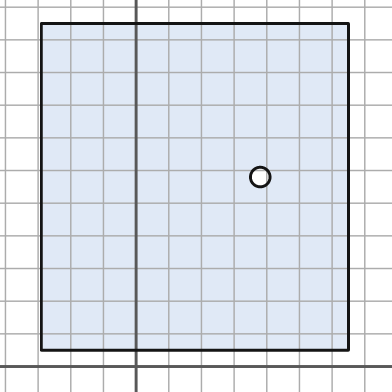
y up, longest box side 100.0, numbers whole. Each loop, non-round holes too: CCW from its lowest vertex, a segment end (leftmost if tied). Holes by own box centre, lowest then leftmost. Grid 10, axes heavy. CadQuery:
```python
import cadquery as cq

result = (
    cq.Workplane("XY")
    .moveTo(-29.0, 5.0)
    .lineTo(65.0, 5.0)
    .lineTo(65.0, 105.0)
    .lineTo(-29.0, 105.0)
    .close()
    .moveTo(38.0, 58.0)
    .circle(3.0)
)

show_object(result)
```